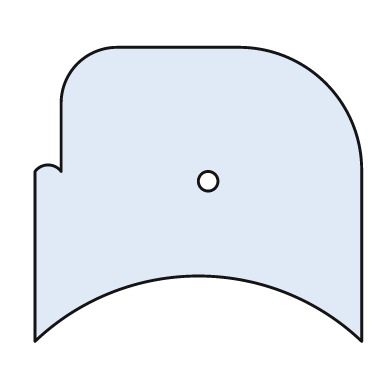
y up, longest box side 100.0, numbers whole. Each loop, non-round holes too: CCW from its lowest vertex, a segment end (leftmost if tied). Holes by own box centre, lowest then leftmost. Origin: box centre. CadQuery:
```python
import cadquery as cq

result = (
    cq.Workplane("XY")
    .moveTo(-50.0, -45.0)
    .threePointArc((0.0, -25.0), (50.0, -45.0))
    .lineTo(50.0, 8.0)
    .threePointArc((39.0, 34.0), (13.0, 45.0))
    .lineTo(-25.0, 45.0)
    .threePointArc((-37.0, 40.0), (-42.0, 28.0))
    .lineTo(-42.0, 7.0)
    .threePointArc((-46.0, 9.0), (-50.0, 7.0))
    .close()
    .moveTo(3.0, 4.0)
    .circle(3.0)
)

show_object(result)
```